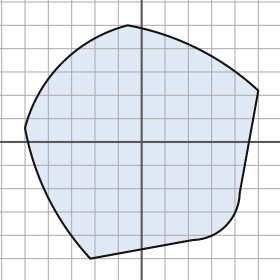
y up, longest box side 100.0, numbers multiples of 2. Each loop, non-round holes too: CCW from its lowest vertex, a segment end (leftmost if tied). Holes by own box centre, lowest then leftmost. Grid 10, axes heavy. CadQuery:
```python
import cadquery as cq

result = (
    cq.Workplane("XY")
    .moveTo(-22.0, -50.0)
    .lineTo(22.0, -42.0)
    .threePointArc((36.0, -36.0), (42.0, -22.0))
    .lineTo(50.0, 22.0)
    .threePointArc((24.0, 40.0), (-6.0, 50.0))
    .threePointArc((-34.0, 34.0), (-50.0, 6.0))
    .threePointArc((-40.0, -24.0), (-22.0, -50.0))
    .close()
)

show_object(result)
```